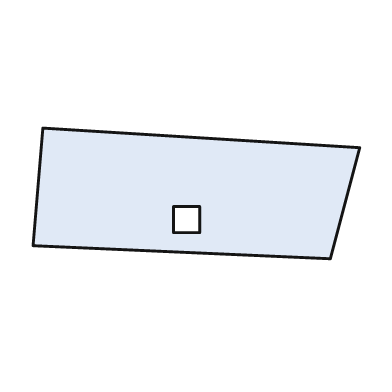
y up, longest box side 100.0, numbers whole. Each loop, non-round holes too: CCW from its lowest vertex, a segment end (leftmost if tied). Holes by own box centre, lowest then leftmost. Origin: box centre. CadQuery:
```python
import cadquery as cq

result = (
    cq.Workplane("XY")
    .moveTo(41.0, -20.0)
    .lineTo(50.0, 14.0)
    .lineTo(-47.0, 20.0)
    .lineTo(-50.0, -16.0)
    .close()
    .moveTo(-7.0, -12.0)
    .lineTo(1.0, -12.0)
    .lineTo(1.0, -4.0)
    .lineTo(-7.0, -4.0)
    .close()
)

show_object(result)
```